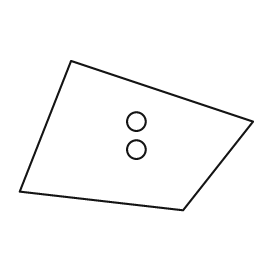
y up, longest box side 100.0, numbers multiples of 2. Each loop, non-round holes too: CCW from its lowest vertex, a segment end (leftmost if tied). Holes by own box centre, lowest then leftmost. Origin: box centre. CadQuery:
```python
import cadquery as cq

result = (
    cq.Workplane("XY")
    .moveTo(20.0, -32.0)
    .lineTo(50.0, 6.0)
    .lineTo(-28.0, 32.0)
    .lineTo(-50.0, -24.0)
    .close()
    .moveTo(0.0, -6.0)
    .circle(4.0)
    .moveTo(0.0, 6.0)
    .circle(4.0)
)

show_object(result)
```